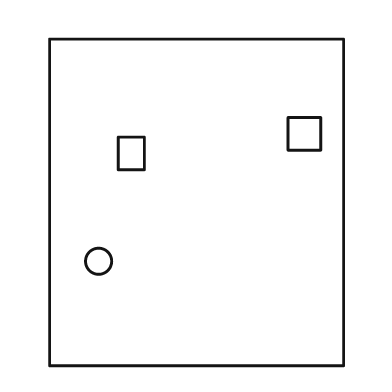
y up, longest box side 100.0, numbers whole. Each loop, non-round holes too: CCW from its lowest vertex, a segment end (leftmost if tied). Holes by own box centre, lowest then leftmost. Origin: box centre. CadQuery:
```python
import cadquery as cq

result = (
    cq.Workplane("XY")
    .moveTo(-45.0, -50.0)
    .lineTo(45.0, -50.0)
    .lineTo(45.0, 50.0)
    .lineTo(-45.0, 50.0)
    .close()
    .moveTo(-30.0, -18.0)
    .circle(4.0)
    .moveTo(-24.0, 10.0)
    .lineTo(-16.0, 10.0)
    .lineTo(-16.0, 20.0)
    .lineTo(-24.0, 20.0)
    .close()
    .moveTo(28.0, 16.0)
    .lineTo(38.0, 16.0)
    .lineTo(38.0, 26.0)
    .lineTo(28.0, 26.0)
    .close()
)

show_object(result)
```